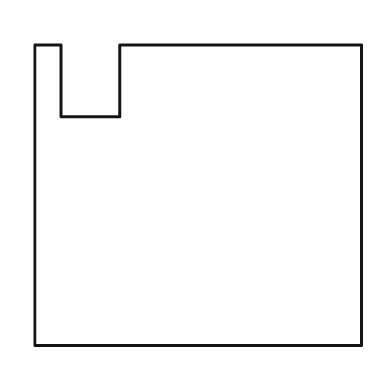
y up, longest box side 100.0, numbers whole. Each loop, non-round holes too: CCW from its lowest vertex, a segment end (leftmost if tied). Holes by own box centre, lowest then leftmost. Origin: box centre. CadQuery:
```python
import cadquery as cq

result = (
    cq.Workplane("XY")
    .moveTo(-50.0, -46.0)
    .lineTo(50.0, -46.0)
    .lineTo(50.0, 46.0)
    .lineTo(-24.0, 46.0)
    .lineTo(-24.0, 24.0)
    .lineTo(-42.0, 24.0)
    .lineTo(-42.0, 46.0)
    .lineTo(-50.0, 46.0)
    .close()
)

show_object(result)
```